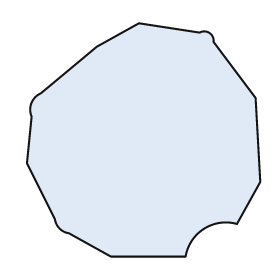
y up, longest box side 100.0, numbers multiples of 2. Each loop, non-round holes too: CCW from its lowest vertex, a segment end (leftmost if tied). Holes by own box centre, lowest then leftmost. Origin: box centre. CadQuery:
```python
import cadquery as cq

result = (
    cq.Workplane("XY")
    .moveTo(-14.0, -50.0)
    .lineTo(18.0, -50.0)
    .threePointArc((26.0, -38.0), (40.0, -36.0))
    .lineTo(50.0, -18.0)
    .lineTo(48.0, 18.0)
    .lineTo(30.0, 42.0)
    .threePointArc((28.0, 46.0), (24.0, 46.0))
    .lineTo(-2.0, 50.0)
    .lineTo(-20.0, 40.0)
    .lineTo(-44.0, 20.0)
    .threePointArc((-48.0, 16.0), (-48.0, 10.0))
    .lineTo(-50.0, -10.0)
    .lineTo(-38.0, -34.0)
    .threePointArc((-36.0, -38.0), (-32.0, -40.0))
    .close()
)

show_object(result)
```